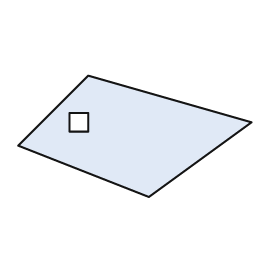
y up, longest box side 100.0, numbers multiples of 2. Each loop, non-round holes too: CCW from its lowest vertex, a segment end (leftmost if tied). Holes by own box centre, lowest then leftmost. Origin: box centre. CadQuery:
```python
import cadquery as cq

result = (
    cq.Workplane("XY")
    .moveTo(6.0, -26.0)
    .lineTo(50.0, 6.0)
    .lineTo(-20.0, 26.0)
    .lineTo(-50.0, -4.0)
    .close()
    .moveTo(-28.0, 2.0)
    .lineTo(-20.0, 2.0)
    .lineTo(-20.0, 10.0)
    .lineTo(-28.0, 10.0)
    .close()
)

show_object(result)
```